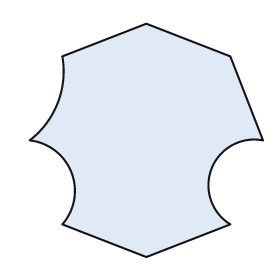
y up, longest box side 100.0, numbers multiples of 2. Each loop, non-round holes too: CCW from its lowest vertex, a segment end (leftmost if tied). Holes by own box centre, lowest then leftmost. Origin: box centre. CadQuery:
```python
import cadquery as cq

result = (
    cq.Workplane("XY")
    .moveTo(0.0, -50.0)
    .lineTo(36.0, -36.0)
    .threePointArc((28.0, -12.0), (50.0, 0.0))
    .lineTo(36.0, 36.0)
    .lineTo(0.0, 50.0)
    .lineTo(-36.0, 36.0)
    .threePointArc((-38.0, 16.0), (-50.0, 0.0))
    .threePointArc((-32.0, -14.0), (-36.0, -36.0))
    .close()
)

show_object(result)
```